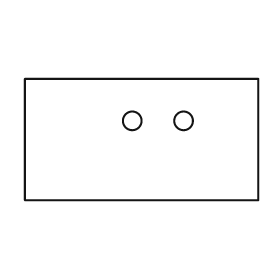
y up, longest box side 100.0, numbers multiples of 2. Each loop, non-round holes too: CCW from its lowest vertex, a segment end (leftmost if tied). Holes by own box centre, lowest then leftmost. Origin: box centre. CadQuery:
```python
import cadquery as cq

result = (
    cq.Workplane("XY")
    .moveTo(-50.0, -26.0)
    .lineTo(50.0, -26.0)
    .lineTo(50.0, 26.0)
    .lineTo(-50.0, 26.0)
    .close()
    .moveTo(-4.0, 8.0)
    .circle(4.0)
    .moveTo(18.0, 8.0)
    .circle(4.0)
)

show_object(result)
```